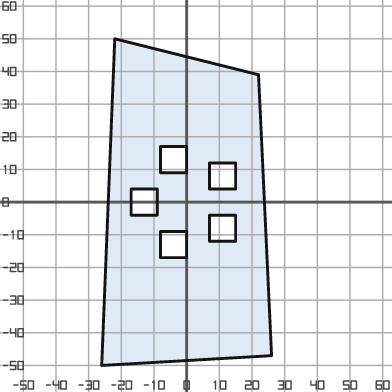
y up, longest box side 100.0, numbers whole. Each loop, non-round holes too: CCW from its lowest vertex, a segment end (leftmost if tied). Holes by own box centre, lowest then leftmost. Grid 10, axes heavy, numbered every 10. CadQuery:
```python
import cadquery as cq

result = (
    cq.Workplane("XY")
    .moveTo(-26.0, -50.0)
    .lineTo(26.0, -47.0)
    .lineTo(22.0, 39.0)
    .lineTo(-22.0, 50.0)
    .close()
    .moveTo(-8.0, -17.0)
    .lineTo(0.0, -17.0)
    .lineTo(0.0, -9.0)
    .lineTo(-8.0, -9.0)
    .close()
    .moveTo(7.0, -12.0)
    .lineTo(15.0, -12.0)
    .lineTo(15.0, -4.0)
    .lineTo(7.0, -4.0)
    .close()
    .moveTo(-17.0, -4.0)
    .lineTo(-9.0, -4.0)
    .lineTo(-9.0, 4.0)
    .lineTo(-17.0, 4.0)
    .close()
    .moveTo(7.0, 4.0)
    .lineTo(15.0, 4.0)
    .lineTo(15.0, 12.0)
    .lineTo(7.0, 12.0)
    .close()
    .moveTo(-8.0, 9.0)
    .lineTo(0.0, 9.0)
    .lineTo(0.0, 17.0)
    .lineTo(-8.0, 17.0)
    .close()
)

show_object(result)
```